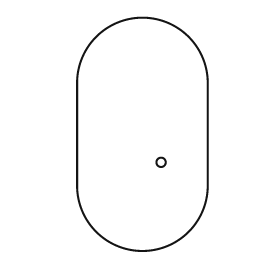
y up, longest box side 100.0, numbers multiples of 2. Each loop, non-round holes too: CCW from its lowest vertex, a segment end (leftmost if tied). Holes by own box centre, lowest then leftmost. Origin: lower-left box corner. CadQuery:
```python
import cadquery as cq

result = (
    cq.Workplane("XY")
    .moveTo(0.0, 28.0)
    .threePointArc((28.0, 0.0), (56.0, 28.0))
    .lineTo(56.0, 72.0)
    .threePointArc((28.0, 100.0), (0.0, 72.0))
    .close()
    .moveTo(36.0, 38.0)
    .circle(2.0)
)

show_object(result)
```